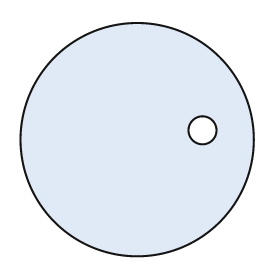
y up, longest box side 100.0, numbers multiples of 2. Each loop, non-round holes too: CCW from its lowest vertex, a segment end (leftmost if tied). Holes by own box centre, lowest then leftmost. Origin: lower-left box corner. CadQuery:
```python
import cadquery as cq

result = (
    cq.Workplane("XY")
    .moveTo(50.0, 50.0)
    .circle(50.0)
    .moveTo(78.0, 54.0)
    .circle(6.0)
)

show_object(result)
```